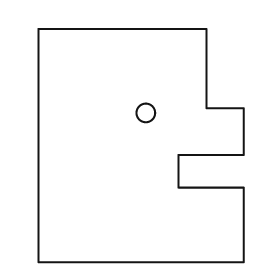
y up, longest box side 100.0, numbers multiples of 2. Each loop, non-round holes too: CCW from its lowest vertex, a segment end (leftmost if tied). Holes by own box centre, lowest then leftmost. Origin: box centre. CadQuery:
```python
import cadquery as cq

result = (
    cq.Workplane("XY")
    .moveTo(-44.0, -50.0)
    .lineTo(44.0, -50.0)
    .lineTo(44.0, -18.0)
    .lineTo(16.0, -18.0)
    .lineTo(16.0, -4.0)
    .lineTo(44.0, -4.0)
    .lineTo(44.0, 16.0)
    .lineTo(28.0, 16.0)
    .lineTo(28.0, 50.0)
    .lineTo(-44.0, 50.0)
    .close()
    .moveTo(2.0, 14.0)
    .circle(4.0)
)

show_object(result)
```